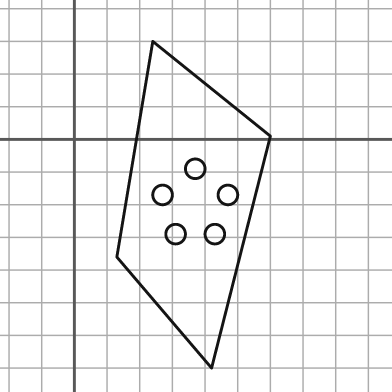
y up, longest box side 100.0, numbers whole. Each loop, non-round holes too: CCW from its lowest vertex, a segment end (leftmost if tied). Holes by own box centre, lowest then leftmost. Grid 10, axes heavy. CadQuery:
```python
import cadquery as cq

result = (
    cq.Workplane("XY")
    .moveTo(42.0, -70.0)
    .lineTo(60.0, 1.0)
    .lineTo(24.0, 30.0)
    .lineTo(13.0, -36.0)
    .close()
    .moveTo(31.0, -29.0)
    .circle(3.0)
    .moveTo(43.0, -29.0)
    .circle(3.0)
    .moveTo(27.0, -17.0)
    .circle(3.0)
    .moveTo(47.0, -17.0)
    .circle(3.0)
    .moveTo(37.0, -9.0)
    .circle(3.0)
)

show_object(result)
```